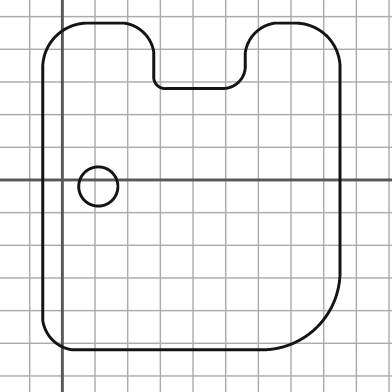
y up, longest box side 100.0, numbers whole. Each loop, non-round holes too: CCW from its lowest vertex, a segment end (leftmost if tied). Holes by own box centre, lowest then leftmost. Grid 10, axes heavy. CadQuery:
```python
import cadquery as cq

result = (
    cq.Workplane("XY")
    .moveTo(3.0, -52.0)
    .lineTo(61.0, -52.0)
    .threePointArc((78.0, -45.0), (85.0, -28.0))
    .lineTo(85.0, 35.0)
    .threePointArc((81.0, 44.0), (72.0, 48.0))
    .lineTo(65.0, 48.0)
    .threePointArc((59.0, 45.0), (56.0, 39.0))
    .lineTo(56.0, 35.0)
    .threePointArc((54.0, 30.0), (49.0, 28.0))
    .lineTo(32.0, 28.0)
    .threePointArc((29.0, 29.0), (28.0, 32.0))
    .lineTo(28.0, 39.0)
    .threePointArc((25.0, 45.0), (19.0, 48.0))
    .lineTo(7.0, 48.0)
    .threePointArc((-2.0, 44.0), (-6.0, 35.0))
    .lineTo(-6.0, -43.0)
    .threePointArc((-3.0, -49.0), (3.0, -52.0))
    .close()
    .moveTo(11.0, -2.0)
    .circle(6.0)
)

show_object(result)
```